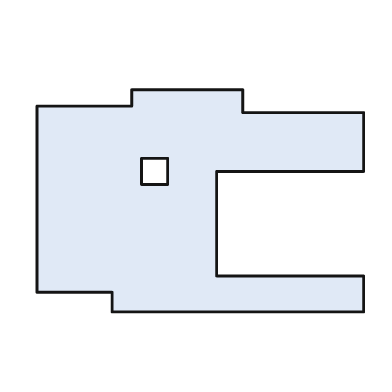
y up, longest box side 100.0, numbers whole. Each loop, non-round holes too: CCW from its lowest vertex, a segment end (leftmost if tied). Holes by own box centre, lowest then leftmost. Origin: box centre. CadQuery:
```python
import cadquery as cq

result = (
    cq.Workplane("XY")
    .moveTo(-27.0, -34.0)
    .lineTo(50.0, -34.0)
    .lineTo(50.0, -23.0)
    .lineTo(5.0, -23.0)
    .lineTo(5.0, 9.0)
    .lineTo(50.0, 9.0)
    .lineTo(50.0, 27.0)
    .lineTo(13.0, 27.0)
    .lineTo(13.0, 34.0)
    .lineTo(-21.0, 34.0)
    .lineTo(-21.0, 29.0)
    .lineTo(-50.0, 29.0)
    .lineTo(-50.0, -28.0)
    .lineTo(-27.0, -28.0)
    .close()
    .moveTo(-18.0, 5.0)
    .lineTo(-10.0, 5.0)
    .lineTo(-10.0, 13.0)
    .lineTo(-18.0, 13.0)
    .close()
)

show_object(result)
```